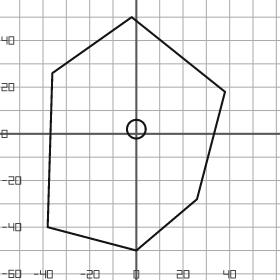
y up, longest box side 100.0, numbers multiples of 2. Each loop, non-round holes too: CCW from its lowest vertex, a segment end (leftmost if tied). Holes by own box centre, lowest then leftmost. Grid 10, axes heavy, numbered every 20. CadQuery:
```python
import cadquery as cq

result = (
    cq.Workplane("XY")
    .moveTo(0.0, -50.0)
    .lineTo(26.0, -28.0)
    .lineTo(38.0, 18.0)
    .lineTo(-2.0, 50.0)
    .lineTo(-36.0, 26.0)
    .lineTo(-38.0, -40.0)
    .close()
    .moveTo(0.0, 2.0)
    .circle(4.0)
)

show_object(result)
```